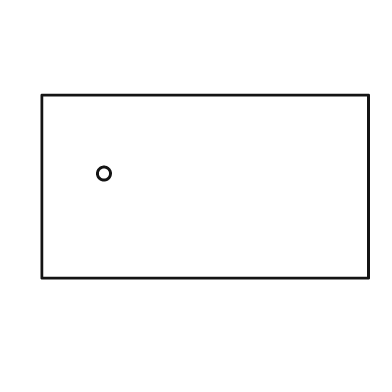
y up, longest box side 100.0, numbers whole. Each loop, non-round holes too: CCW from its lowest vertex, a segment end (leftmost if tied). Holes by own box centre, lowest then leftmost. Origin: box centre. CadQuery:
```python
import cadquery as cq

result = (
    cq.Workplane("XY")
    .moveTo(-50.0, -28.0)
    .lineTo(50.0, -28.0)
    .lineTo(50.0, 28.0)
    .lineTo(-50.0, 28.0)
    .close()
    .moveTo(-31.0, 4.0)
    .circle(2.0)
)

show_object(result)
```